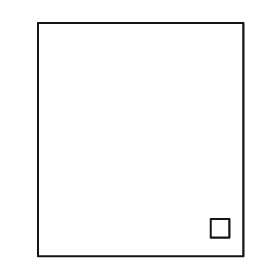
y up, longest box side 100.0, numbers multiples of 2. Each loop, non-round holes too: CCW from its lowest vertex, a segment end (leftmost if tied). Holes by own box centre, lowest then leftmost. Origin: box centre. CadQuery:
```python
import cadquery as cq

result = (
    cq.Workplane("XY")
    .moveTo(-44.0, -50.0)
    .lineTo(44.0, -50.0)
    .lineTo(44.0, 50.0)
    .lineTo(-44.0, 50.0)
    .close()
    .moveTo(30.0, -42.0)
    .lineTo(38.0, -42.0)
    .lineTo(38.0, -34.0)
    .lineTo(30.0, -34.0)
    .close()
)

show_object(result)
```